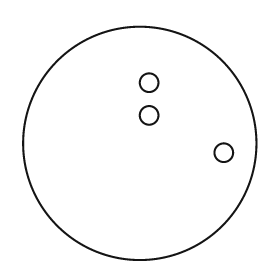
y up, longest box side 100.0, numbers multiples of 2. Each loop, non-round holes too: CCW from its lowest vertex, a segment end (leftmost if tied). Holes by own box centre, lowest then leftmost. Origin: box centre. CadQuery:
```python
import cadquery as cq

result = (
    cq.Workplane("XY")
    .moveTo(0.0, 0.0)
    .circle(50.0)
    .moveTo(36.0, -4.0)
    .circle(4.0)
    .moveTo(4.0, 12.0)
    .circle(4.0)
    .moveTo(4.0, 26.0)
    .circle(4.0)
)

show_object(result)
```